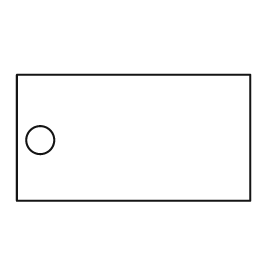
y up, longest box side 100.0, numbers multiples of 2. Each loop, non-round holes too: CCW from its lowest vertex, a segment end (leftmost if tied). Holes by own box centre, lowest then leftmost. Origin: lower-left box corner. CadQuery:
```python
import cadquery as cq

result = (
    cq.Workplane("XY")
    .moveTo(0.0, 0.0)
    .lineTo(100.0, 0.0)
    .lineTo(100.0, 54.0)
    .lineTo(0.0, 54.0)
    .close()
    .moveTo(10.0, 26.0)
    .circle(6.0)
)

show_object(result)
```